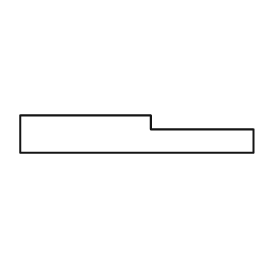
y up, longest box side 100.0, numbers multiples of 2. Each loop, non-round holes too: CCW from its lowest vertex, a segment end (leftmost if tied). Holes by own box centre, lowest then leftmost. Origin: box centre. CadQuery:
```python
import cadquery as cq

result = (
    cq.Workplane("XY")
    .moveTo(-50.0, -8.0)
    .lineTo(50.0, -8.0)
    .lineTo(50.0, 2.0)
    .lineTo(6.0, 2.0)
    .lineTo(6.0, 8.0)
    .lineTo(-50.0, 8.0)
    .close()
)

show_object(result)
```